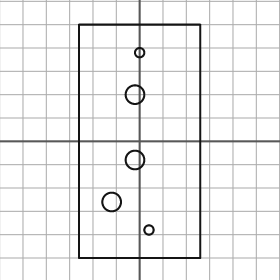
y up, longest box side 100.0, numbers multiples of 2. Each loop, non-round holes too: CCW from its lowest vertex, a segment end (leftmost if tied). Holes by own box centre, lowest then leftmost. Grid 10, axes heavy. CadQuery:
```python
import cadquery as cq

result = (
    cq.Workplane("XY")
    .moveTo(-26.0, -50.0)
    .lineTo(26.0, -50.0)
    .lineTo(26.0, 50.0)
    .lineTo(-26.0, 50.0)
    .close()
    .moveTo(4.0, -38.0)
    .circle(2.0)
    .moveTo(-12.0, -26.0)
    .circle(4.0)
    .moveTo(-2.0, -8.0)
    .circle(4.0)
    .moveTo(-2.0, 20.0)
    .circle(4.0)
    .moveTo(0.0, 38.0)
    .circle(2.0)
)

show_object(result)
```